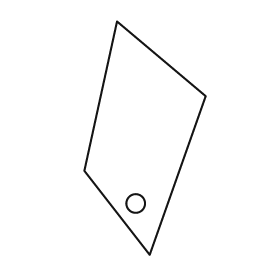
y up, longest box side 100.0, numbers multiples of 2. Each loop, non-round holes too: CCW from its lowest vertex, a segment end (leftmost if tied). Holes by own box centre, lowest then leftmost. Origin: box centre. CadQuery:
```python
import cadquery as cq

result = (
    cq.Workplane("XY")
    .moveTo(2.0, -50.0)
    .lineTo(26.0, 18.0)
    .lineTo(-12.0, 50.0)
    .lineTo(-26.0, -14.0)
    .close()
    .moveTo(-4.0, -28.0)
    .circle(4.0)
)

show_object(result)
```